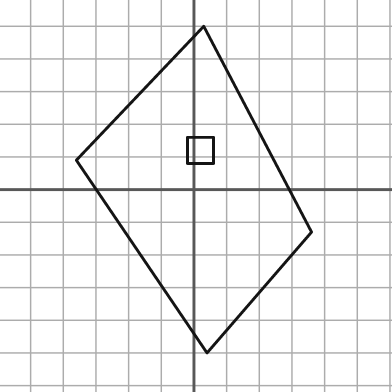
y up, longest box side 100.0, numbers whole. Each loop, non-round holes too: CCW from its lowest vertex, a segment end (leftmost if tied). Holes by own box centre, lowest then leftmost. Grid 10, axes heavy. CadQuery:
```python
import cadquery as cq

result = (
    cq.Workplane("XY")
    .moveTo(4.0, -50.0)
    .lineTo(36.0, -13.0)
    .lineTo(3.0, 50.0)
    .lineTo(-36.0, 9.0)
    .close()
    .moveTo(-2.0, 8.0)
    .lineTo(6.0, 8.0)
    .lineTo(6.0, 16.0)
    .lineTo(-2.0, 16.0)
    .close()
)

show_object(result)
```